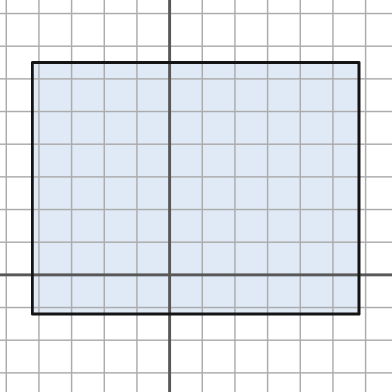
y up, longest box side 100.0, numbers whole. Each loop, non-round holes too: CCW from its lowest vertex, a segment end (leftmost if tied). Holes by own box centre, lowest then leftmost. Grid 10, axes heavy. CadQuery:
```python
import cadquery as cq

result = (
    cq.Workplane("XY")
    .moveTo(-42.0, -12.0)
    .lineTo(58.0, -12.0)
    .lineTo(58.0, 65.0)
    .lineTo(-42.0, 65.0)
    .close()
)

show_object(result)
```